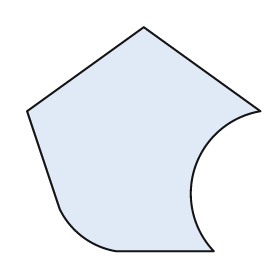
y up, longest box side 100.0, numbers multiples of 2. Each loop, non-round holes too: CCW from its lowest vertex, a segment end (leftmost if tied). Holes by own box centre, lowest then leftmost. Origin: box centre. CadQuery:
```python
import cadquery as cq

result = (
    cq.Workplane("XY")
    .moveTo(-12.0, -48.0)
    .lineTo(30.0, -48.0)
    .threePointArc((22.0, -12.0), (50.0, 12.0))
    .lineTo(0.0, 48.0)
    .lineTo(-50.0, 12.0)
    .lineTo(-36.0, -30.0)
    .threePointArc((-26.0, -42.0), (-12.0, -48.0))
    .close()
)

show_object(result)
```